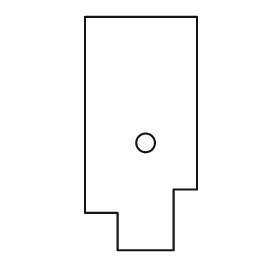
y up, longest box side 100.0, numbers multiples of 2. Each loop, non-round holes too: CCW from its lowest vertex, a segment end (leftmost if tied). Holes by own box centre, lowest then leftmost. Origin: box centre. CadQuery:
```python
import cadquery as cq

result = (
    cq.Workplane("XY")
    .moveTo(-10.0, -50.0)
    .lineTo(14.0, -50.0)
    .lineTo(14.0, -24.0)
    .lineTo(24.0, -24.0)
    .lineTo(24.0, 50.0)
    .lineTo(-24.0, 50.0)
    .lineTo(-24.0, -34.0)
    .lineTo(-10.0, -34.0)
    .close()
    .moveTo(2.0, -4.0)
    .circle(4.0)
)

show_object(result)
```